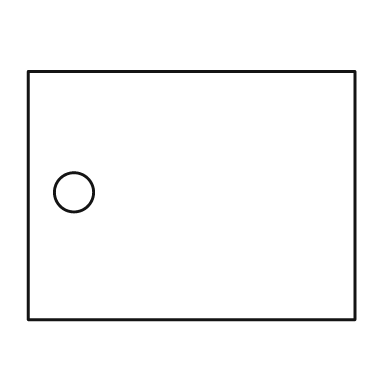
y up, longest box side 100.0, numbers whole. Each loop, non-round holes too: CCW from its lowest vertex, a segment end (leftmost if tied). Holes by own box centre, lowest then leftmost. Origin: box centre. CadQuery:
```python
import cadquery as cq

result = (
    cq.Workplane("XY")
    .moveTo(-50.0, -38.0)
    .lineTo(50.0, -38.0)
    .lineTo(50.0, 38.0)
    .lineTo(-50.0, 38.0)
    .close()
    .moveTo(-36.0, 1.0)
    .circle(6.0)
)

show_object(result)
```